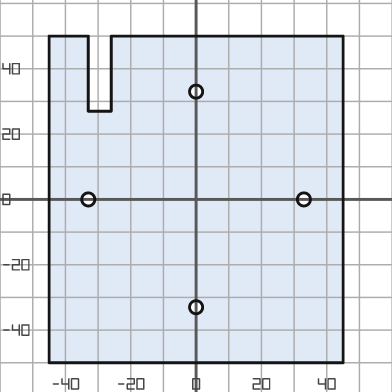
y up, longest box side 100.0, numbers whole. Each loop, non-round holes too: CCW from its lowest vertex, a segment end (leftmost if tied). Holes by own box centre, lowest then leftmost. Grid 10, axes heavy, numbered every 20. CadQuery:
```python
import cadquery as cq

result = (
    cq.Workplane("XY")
    .moveTo(-45.0, -50.0)
    .lineTo(45.0, -50.0)
    .lineTo(45.0, 50.0)
    .lineTo(-26.0, 50.0)
    .lineTo(-26.0, 27.0)
    .lineTo(-33.0, 27.0)
    .lineTo(-33.0, 50.0)
    .lineTo(-45.0, 50.0)
    .close()
    .moveTo(0.0, -33.0)
    .circle(2.0)
    .moveTo(-33.0, 0.0)
    .circle(2.0)
    .moveTo(33.0, 0.0)
    .circle(2.0)
    .moveTo(0.0, 33.0)
    .circle(2.0)
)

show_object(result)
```